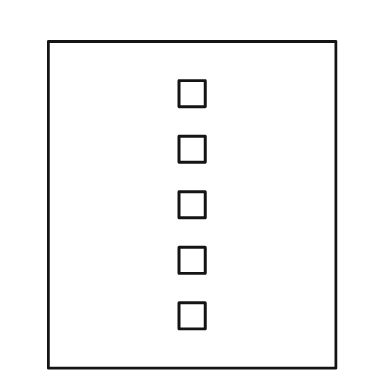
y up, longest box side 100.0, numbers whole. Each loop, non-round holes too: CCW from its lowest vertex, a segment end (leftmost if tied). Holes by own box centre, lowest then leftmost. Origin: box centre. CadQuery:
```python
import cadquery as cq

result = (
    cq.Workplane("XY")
    .moveTo(-44.0, -50.0)
    .lineTo(44.0, -50.0)
    .lineTo(44.0, 50.0)
    .lineTo(-44.0, 50.0)
    .close()
    .moveTo(-4.0, -38.0)
    .lineTo(4.0, -38.0)
    .lineTo(4.0, -30.0)
    .lineTo(-4.0, -30.0)
    .close()
    .moveTo(-4.0, -21.0)
    .lineTo(4.0, -21.0)
    .lineTo(4.0, -13.0)
    .lineTo(-4.0, -13.0)
    .close()
    .moveTo(-4.0, -4.0)
    .lineTo(4.0, -4.0)
    .lineTo(4.0, 4.0)
    .lineTo(-4.0, 4.0)
    .close()
    .moveTo(-4.0, 13.0)
    .lineTo(4.0, 13.0)
    .lineTo(4.0, 21.0)
    .lineTo(-4.0, 21.0)
    .close()
    .moveTo(-4.0, 30.0)
    .lineTo(4.0, 30.0)
    .lineTo(4.0, 38.0)
    .lineTo(-4.0, 38.0)
    .close()
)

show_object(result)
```